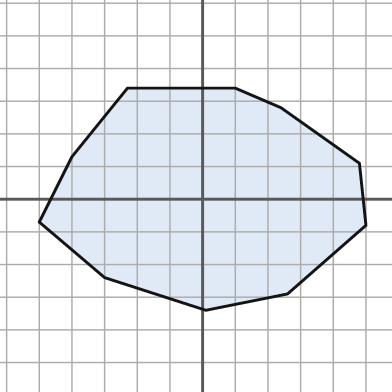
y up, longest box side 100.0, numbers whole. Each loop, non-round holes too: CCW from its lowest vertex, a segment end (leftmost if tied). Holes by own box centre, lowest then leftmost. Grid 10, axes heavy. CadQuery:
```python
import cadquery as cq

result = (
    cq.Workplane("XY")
    .moveTo(1.0, -34.0)
    .lineTo(26.0, -29.0)
    .lineTo(50.0, -8.0)
    .lineTo(48.0, 11.0)
    .lineTo(24.0, 28.0)
    .lineTo(10.0, 34.0)
    .lineTo(-23.0, 34.0)
    .lineTo(-40.0, 13.0)
    .lineTo(-50.0, -7.0)
    .lineTo(-30.0, -24.0)
    .close()
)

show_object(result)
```